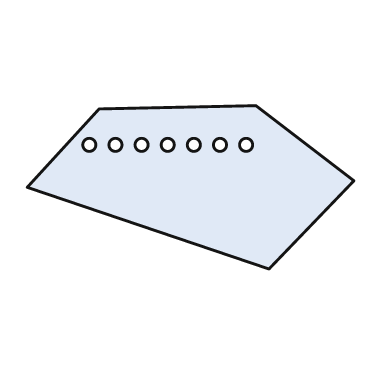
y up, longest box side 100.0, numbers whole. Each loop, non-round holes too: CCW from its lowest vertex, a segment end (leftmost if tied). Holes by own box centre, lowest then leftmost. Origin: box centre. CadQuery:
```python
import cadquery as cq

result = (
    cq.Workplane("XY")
    .moveTo(24.0, -25.0)
    .lineTo(50.0, 2.0)
    .lineTo(20.0, 25.0)
    .lineTo(-28.0, 24.0)
    .lineTo(-50.0, 0.0)
    .close()
    .moveTo(-31.0, 13.0)
    .circle(2.0)
    .moveTo(-23.0, 13.0)
    .circle(2.0)
    .moveTo(-15.0, 13.0)
    .circle(2.0)
    .moveTo(-7.0, 13.0)
    .circle(2.0)
    .moveTo(1.0, 13.0)
    .circle(2.0)
    .moveTo(9.0, 13.0)
    .circle(2.0)
    .moveTo(17.0, 13.0)
    .circle(2.0)
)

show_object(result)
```